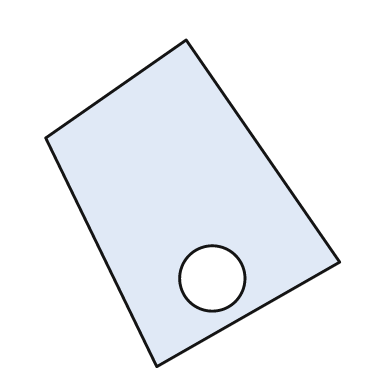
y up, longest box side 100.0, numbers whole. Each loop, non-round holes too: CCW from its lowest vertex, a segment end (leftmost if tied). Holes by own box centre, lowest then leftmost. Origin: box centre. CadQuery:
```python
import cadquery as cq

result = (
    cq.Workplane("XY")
    .moveTo(-11.0, -50.0)
    .lineTo(45.0, -18.0)
    .lineTo(-2.0, 50.0)
    .lineTo(-45.0, 20.0)
    .close()
    .moveTo(6.0, -23.0)
    .circle(10.0)
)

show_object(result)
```